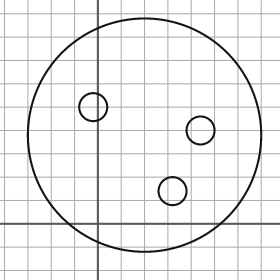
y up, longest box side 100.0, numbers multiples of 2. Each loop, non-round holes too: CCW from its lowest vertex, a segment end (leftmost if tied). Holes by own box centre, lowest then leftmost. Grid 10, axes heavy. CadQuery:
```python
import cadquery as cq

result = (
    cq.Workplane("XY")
    .moveTo(20.0, 38.0)
    .circle(50.0)
    .moveTo(32.0, 14.0)
    .circle(6.0)
    .moveTo(44.0, 40.0)
    .circle(6.0)
    .moveTo(-2.0, 50.0)
    .circle(6.0)
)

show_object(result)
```